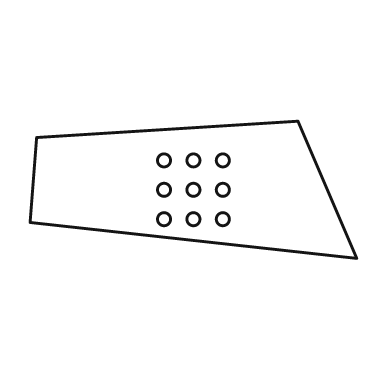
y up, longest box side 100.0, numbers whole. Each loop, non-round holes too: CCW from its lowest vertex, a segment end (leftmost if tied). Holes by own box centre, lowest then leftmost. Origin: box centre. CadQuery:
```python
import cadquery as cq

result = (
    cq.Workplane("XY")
    .moveTo(50.0, -21.0)
    .lineTo(32.0, 21.0)
    .lineTo(-48.0, 16.0)
    .lineTo(-50.0, -10.0)
    .close()
    .moveTo(-9.0, -9.0)
    .circle(2.0)
    .moveTo(0.0, -9.0)
    .circle(2.0)
    .moveTo(9.0, -9.0)
    .circle(2.0)
    .moveTo(-9.0, 0.0)
    .circle(2.0)
    .moveTo(0.0, 0.0)
    .circle(2.0)
    .moveTo(9.0, 0.0)
    .circle(2.0)
    .moveTo(-9.0, 9.0)
    .circle(2.0)
    .moveTo(0.0, 9.0)
    .circle(2.0)
    .moveTo(9.0, 9.0)
    .circle(2.0)
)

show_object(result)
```